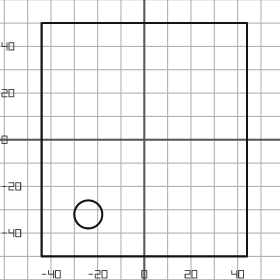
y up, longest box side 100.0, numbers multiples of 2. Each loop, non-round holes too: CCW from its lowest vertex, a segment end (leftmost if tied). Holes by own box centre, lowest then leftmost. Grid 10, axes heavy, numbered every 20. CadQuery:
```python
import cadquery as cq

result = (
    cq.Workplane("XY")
    .moveTo(-44.0, -50.0)
    .lineTo(44.0, -50.0)
    .lineTo(44.0, 50.0)
    .lineTo(-44.0, 50.0)
    .close()
    .moveTo(-24.0, -32.0)
    .circle(6.0)
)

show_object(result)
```